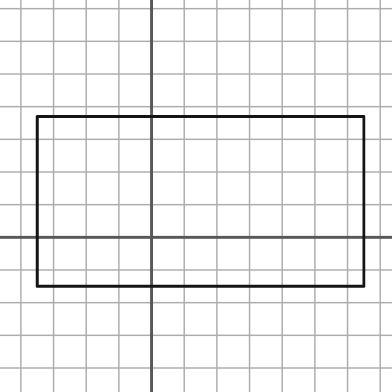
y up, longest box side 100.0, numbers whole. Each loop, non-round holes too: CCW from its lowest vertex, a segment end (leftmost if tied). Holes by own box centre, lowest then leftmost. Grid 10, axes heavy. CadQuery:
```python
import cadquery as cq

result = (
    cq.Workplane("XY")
    .moveTo(-35.0, -15.0)
    .lineTo(65.0, -15.0)
    .lineTo(65.0, 37.0)
    .lineTo(-35.0, 37.0)
    .close()
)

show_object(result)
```